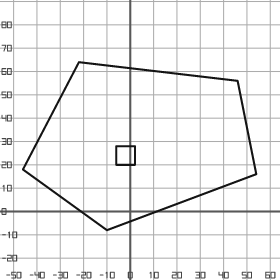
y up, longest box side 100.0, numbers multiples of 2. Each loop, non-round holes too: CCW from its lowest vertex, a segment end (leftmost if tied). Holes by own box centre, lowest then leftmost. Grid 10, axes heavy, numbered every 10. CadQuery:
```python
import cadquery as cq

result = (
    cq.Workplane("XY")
    .moveTo(-10.0, -8.0)
    .lineTo(54.0, 16.0)
    .lineTo(46.0, 56.0)
    .lineTo(-22.0, 64.0)
    .lineTo(-46.0, 18.0)
    .close()
    .moveTo(-6.0, 20.0)
    .lineTo(2.0, 20.0)
    .lineTo(2.0, 28.0)
    .lineTo(-6.0, 28.0)
    .close()
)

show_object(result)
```